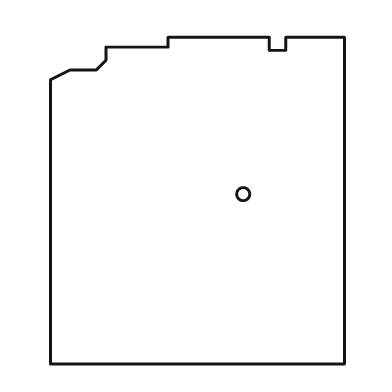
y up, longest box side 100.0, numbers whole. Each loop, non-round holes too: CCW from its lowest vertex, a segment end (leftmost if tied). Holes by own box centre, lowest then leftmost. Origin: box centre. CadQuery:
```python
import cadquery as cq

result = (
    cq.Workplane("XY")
    .moveTo(-45.0, -50.0)
    .lineTo(45.0, -50.0)
    .lineTo(45.0, 50.0)
    .lineTo(27.0, 50.0)
    .lineTo(27.0, 46.0)
    .lineTo(22.0, 46.0)
    .lineTo(22.0, 50.0)
    .lineTo(-9.0, 50.0)
    .lineTo(-9.0, 47.0)
    .lineTo(-28.0, 47.0)
    .lineTo(-28.0, 43.0)
    .lineTo(-31.0, 40.0)
    .lineTo(-39.0, 40.0)
    .lineTo(-45.0, 37.0)
    .close()
    .moveTo(14.0, 2.0)
    .circle(2.0)
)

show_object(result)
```